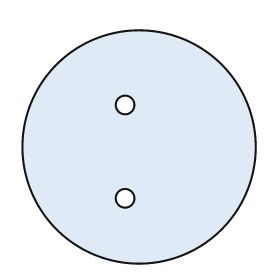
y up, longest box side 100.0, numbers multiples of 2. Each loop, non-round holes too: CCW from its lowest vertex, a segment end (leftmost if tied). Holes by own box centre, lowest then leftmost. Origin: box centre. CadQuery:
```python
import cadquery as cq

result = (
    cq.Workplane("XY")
    .moveTo(0.0, 0.0)
    .circle(50.0)
    .moveTo(-6.0, -22.0)
    .circle(4.0)
    .moveTo(-6.0, 18.0)
    .circle(4.0)
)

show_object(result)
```